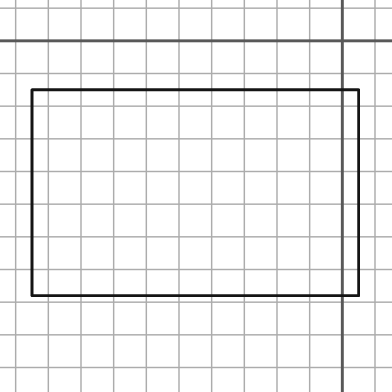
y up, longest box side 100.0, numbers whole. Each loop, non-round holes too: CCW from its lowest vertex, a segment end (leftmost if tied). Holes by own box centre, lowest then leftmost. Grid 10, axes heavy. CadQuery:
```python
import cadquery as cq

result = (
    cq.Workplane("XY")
    .moveTo(-95.0, -78.0)
    .lineTo(5.0, -78.0)
    .lineTo(5.0, -15.0)
    .lineTo(-95.0, -15.0)
    .close()
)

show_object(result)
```